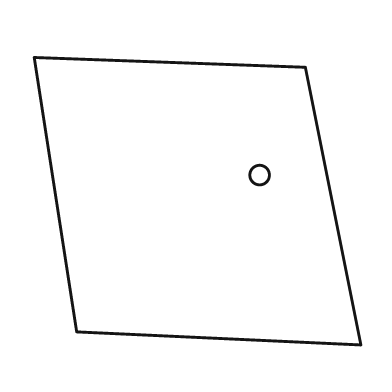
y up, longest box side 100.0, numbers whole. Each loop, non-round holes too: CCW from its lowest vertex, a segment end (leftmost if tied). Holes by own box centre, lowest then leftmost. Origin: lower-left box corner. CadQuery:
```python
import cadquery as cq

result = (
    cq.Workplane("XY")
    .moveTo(100.0, 0.0)
    .lineTo(83.0, 85.0)
    .lineTo(0.0, 88.0)
    .lineTo(13.0, 4.0)
    .close()
    .moveTo(69.0, 52.0)
    .circle(3.0)
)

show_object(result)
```